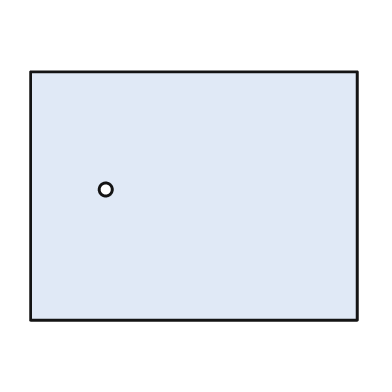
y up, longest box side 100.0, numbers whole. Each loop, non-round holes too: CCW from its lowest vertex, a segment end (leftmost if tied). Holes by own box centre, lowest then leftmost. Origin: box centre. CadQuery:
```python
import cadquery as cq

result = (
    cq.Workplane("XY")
    .moveTo(-50.0, -38.0)
    .lineTo(50.0, -38.0)
    .lineTo(50.0, 38.0)
    .lineTo(-50.0, 38.0)
    .close()
    .moveTo(-27.0, 2.0)
    .circle(2.0)
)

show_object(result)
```